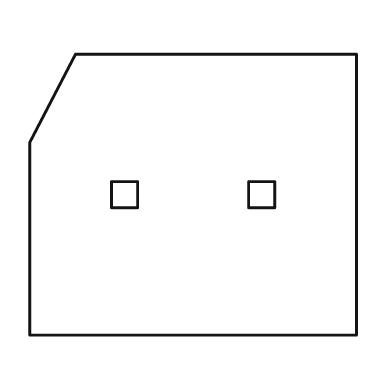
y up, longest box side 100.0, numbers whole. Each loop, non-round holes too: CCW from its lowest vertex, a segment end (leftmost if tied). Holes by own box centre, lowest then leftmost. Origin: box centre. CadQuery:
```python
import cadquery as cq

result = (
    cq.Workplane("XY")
    .moveTo(-50.0, -43.0)
    .lineTo(50.0, -43.0)
    .lineTo(50.0, 43.0)
    .lineTo(-36.0, 43.0)
    .lineTo(-50.0, 16.0)
    .close()
    .moveTo(-25.0, -4.0)
    .lineTo(-17.0, -4.0)
    .lineTo(-17.0, 4.0)
    .lineTo(-25.0, 4.0)
    .close()
    .moveTo(17.0, -4.0)
    .lineTo(25.0, -4.0)
    .lineTo(25.0, 4.0)
    .lineTo(17.0, 4.0)
    .close()
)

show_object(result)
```